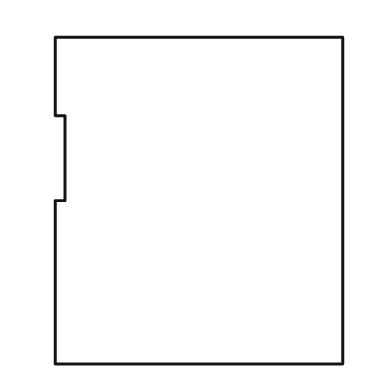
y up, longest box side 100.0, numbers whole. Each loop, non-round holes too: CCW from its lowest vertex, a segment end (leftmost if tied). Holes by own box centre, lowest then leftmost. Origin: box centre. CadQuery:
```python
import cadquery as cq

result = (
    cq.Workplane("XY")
    .moveTo(-44.0, -50.0)
    .lineTo(44.0, -50.0)
    .lineTo(44.0, 50.0)
    .lineTo(-44.0, 50.0)
    .lineTo(-44.0, 26.0)
    .lineTo(-41.0, 26.0)
    .lineTo(-41.0, 0.0)
    .lineTo(-44.0, 0.0)
    .close()
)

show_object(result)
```